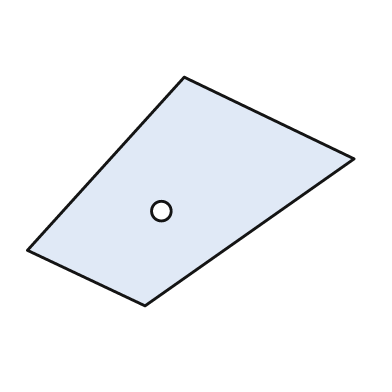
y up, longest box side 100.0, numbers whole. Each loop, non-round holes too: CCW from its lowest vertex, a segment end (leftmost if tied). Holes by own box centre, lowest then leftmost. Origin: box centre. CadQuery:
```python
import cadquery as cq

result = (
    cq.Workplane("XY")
    .moveTo(-14.0, -35.0)
    .lineTo(50.0, 10.0)
    .lineTo(-2.0, 35.0)
    .lineTo(-50.0, -18.0)
    .close()
    .moveTo(-9.0, -6.0)
    .circle(3.0)
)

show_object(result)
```